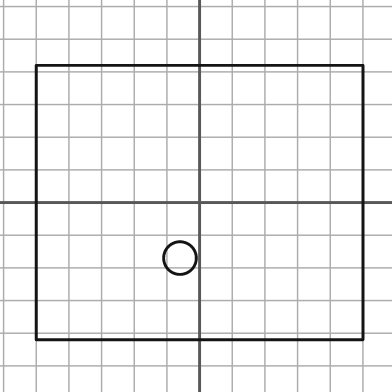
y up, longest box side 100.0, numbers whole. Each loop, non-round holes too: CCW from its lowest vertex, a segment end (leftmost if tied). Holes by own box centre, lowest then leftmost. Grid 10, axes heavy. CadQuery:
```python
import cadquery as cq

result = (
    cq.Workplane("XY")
    .moveTo(-50.0, -42.0)
    .lineTo(50.0, -42.0)
    .lineTo(50.0, 42.0)
    .lineTo(-50.0, 42.0)
    .close()
    .moveTo(-6.0, -17.0)
    .circle(5.0)
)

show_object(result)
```